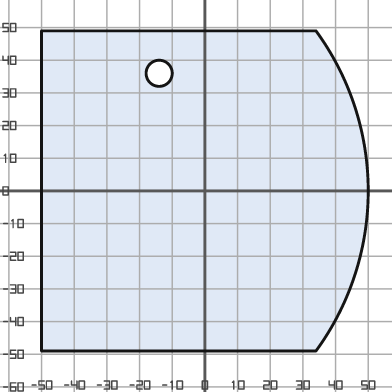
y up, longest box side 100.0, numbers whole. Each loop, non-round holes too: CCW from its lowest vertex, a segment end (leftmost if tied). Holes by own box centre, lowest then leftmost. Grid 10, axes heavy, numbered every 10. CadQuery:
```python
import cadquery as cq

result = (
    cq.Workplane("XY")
    .moveTo(-50.0, -49.0)
    .lineTo(34.0, -49.0)
    .threePointArc((50.0, 0.0), (34.0, 49.0))
    .lineTo(-50.0, 49.0)
    .close()
    .moveTo(-14.0, 36.0)
    .circle(4.0)
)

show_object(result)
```